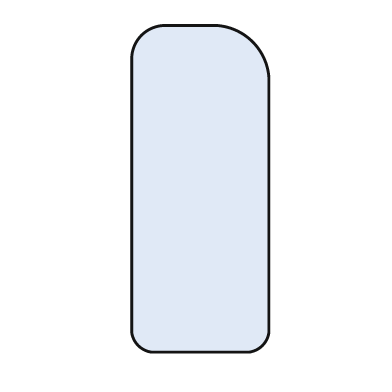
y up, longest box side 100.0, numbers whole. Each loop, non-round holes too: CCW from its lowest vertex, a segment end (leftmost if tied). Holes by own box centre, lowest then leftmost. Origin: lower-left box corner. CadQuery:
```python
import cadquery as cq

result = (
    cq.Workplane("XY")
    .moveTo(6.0, 0.0)
    .lineTo(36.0, 0.0)
    .threePointArc((40.0, 2.0), (42.0, 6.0))
    .lineTo(42.0, 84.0)
    .threePointArc((37.0, 95.0), (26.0, 100.0))
    .lineTo(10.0, 100.0)
    .threePointArc((3.0, 97.0), (0.0, 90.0))
    .lineTo(0.0, 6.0)
    .threePointArc((2.0, 2.0), (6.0, 0.0))
    .close()
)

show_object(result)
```